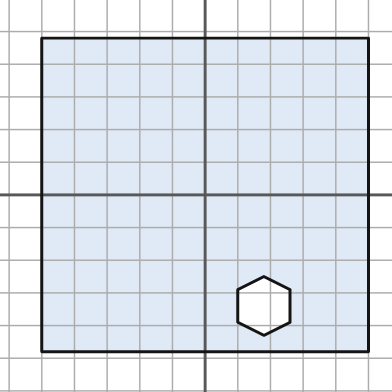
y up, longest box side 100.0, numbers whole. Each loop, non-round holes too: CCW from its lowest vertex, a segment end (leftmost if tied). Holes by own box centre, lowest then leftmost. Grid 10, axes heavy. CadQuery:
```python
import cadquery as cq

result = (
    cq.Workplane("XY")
    .moveTo(-50.0, -48.0)
    .lineTo(50.0, -48.0)
    .lineTo(50.0, 48.0)
    .lineTo(-50.0, 48.0)
    .close()
    .moveTo(18.0, -43.0)
    .lineTo(26.0, -39.0)
    .lineTo(26.0, -29.0)
    .lineTo(18.0, -25.0)
    .lineTo(10.0, -29.0)
    .lineTo(10.0, -39.0)
    .close()
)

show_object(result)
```